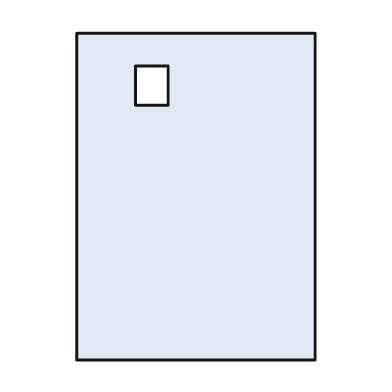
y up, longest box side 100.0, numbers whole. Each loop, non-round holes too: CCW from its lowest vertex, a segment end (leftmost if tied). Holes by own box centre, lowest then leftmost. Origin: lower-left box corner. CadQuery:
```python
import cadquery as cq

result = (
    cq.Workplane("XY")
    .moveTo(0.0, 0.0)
    .lineTo(73.0, 0.0)
    .lineTo(73.0, 100.0)
    .lineTo(0.0, 100.0)
    .close()
    .moveTo(18.0, 78.0)
    .lineTo(28.0, 78.0)
    .lineTo(28.0, 90.0)
    .lineTo(18.0, 90.0)
    .close()
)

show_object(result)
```